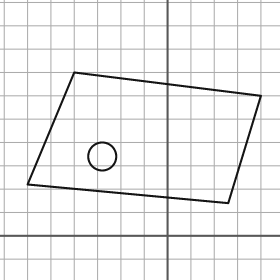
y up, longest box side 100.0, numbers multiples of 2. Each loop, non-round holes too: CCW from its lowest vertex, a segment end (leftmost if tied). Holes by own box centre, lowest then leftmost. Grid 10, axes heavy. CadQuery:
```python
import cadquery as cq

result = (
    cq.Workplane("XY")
    .moveTo(26.0, 14.0)
    .lineTo(40.0, 60.0)
    .lineTo(-40.0, 70.0)
    .lineTo(-60.0, 22.0)
    .close()
    .moveTo(-28.0, 34.0)
    .circle(6.0)
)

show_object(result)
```